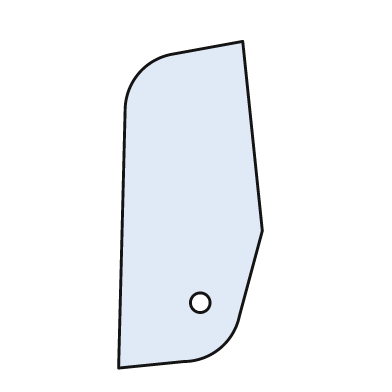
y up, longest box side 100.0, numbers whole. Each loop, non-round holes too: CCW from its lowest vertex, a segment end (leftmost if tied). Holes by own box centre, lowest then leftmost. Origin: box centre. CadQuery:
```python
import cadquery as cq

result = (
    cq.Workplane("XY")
    .moveTo(-22.0, -50.0)
    .lineTo(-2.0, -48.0)
    .threePointArc((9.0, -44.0), (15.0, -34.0))
    .lineTo(22.0, -8.0)
    .lineTo(16.0, 50.0)
    .lineTo(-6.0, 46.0)
    .threePointArc((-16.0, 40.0), (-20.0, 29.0))
    .close()
    .moveTo(3.0, -30.0)
    .circle(3.0)
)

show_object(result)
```